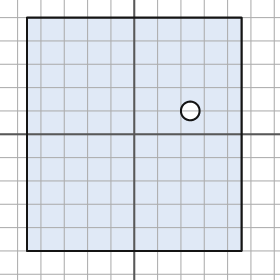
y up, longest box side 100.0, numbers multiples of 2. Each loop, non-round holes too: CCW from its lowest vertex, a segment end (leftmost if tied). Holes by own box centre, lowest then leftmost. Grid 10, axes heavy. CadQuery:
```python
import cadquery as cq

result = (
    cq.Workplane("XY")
    .moveTo(-46.0, -50.0)
    .lineTo(46.0, -50.0)
    .lineTo(46.0, 50.0)
    .lineTo(-46.0, 50.0)
    .close()
    .moveTo(24.0, 10.0)
    .circle(4.0)
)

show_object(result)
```